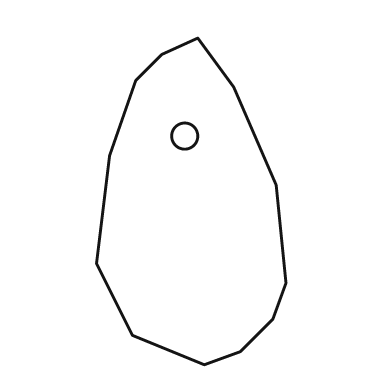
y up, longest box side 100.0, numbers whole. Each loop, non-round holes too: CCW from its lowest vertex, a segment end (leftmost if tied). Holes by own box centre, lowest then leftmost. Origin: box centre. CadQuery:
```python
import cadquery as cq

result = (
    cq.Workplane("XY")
    .moveTo(4.0, -50.0)
    .lineTo(15.0, -46.0)
    .lineTo(25.0, -36.0)
    .lineTo(29.0, -25.0)
    .lineTo(26.0, 5.0)
    .lineTo(13.0, 35.0)
    .lineTo(2.0, 50.0)
    .lineTo(-9.0, 45.0)
    .lineTo(-17.0, 37.0)
    .lineTo(-25.0, 14.0)
    .lineTo(-29.0, -19.0)
    .lineTo(-18.0, -41.0)
    .close()
    .moveTo(-2.0, 20.0)
    .circle(4.0)
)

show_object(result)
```